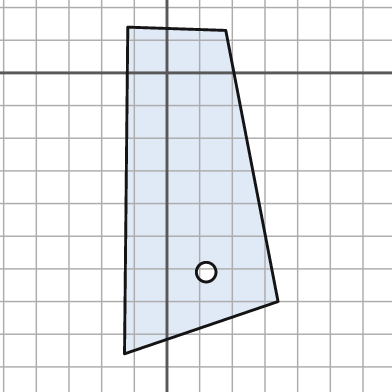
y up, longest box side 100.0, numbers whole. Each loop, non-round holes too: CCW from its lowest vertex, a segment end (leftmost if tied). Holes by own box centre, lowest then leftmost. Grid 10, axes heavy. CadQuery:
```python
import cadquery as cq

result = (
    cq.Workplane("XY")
    .moveTo(-13.0, -86.0)
    .lineTo(34.0, -70.0)
    .lineTo(18.0, 13.0)
    .lineTo(-12.0, 14.0)
    .close()
    .moveTo(12.0, -61.0)
    .circle(3.0)
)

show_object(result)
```